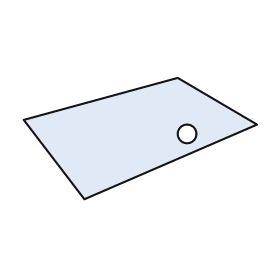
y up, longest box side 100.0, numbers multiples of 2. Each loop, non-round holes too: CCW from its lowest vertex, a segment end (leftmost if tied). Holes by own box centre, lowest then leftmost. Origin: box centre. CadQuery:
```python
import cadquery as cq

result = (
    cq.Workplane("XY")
    .moveTo(-24.0, -26.0)
    .lineTo(50.0, 6.0)
    .lineTo(16.0, 26.0)
    .lineTo(-50.0, 8.0)
    .close()
    .moveTo(20.0, 2.0)
    .circle(4.0)
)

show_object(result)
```